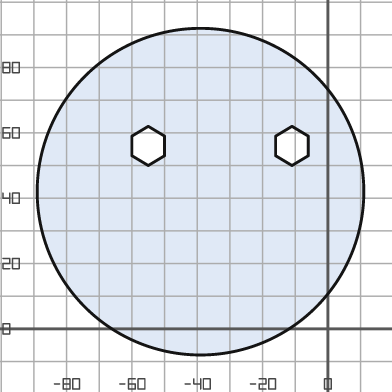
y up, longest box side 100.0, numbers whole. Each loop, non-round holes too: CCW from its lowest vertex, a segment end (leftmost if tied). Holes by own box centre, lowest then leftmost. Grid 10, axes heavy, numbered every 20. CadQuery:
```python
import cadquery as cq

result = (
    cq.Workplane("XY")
    .moveTo(-39.0, 42.0)
    .circle(50.0)
    .moveTo(-55.0, 50.0)
    .lineTo(-50.0, 53.0)
    .lineTo(-50.0, 59.0)
    .lineTo(-55.0, 62.0)
    .lineTo(-60.0, 59.0)
    .lineTo(-60.0, 53.0)
    .close()
    .moveTo(-11.0, 50.0)
    .lineTo(-6.0, 53.0)
    .lineTo(-6.0, 59.0)
    .lineTo(-11.0, 62.0)
    .lineTo(-16.0, 59.0)
    .lineTo(-16.0, 53.0)
    .close()
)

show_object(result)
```